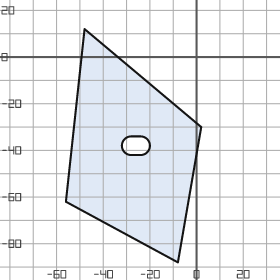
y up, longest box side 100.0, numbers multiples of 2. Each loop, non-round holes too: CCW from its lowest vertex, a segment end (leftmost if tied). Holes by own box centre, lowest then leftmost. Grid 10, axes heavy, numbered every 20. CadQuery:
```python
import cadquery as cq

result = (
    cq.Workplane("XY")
    .moveTo(-8.0, -88.0)
    .lineTo(2.0, -30.0)
    .lineTo(-48.0, 12.0)
    .lineTo(-56.0, -62.0)
    .close()
    .moveTo(-28.0, -42.0)
    .lineTo(-24.0, -42.0)
    .threePointArc((-20.0, -38.0), (-24.0, -34.0))
    .lineTo(-28.0, -34.0)
    .threePointArc((-32.0, -38.0), (-28.0, -42.0))
    .close()
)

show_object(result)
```